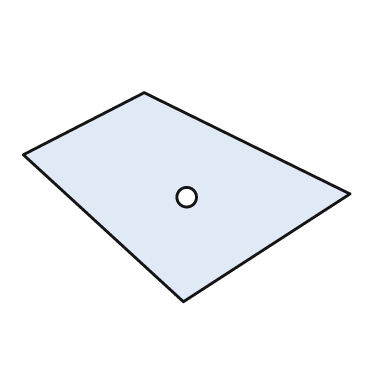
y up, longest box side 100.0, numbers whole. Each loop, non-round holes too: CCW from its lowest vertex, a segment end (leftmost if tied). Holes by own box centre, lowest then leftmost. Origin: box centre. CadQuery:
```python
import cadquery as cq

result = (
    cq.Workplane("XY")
    .moveTo(-1.0, -32.0)
    .lineTo(50.0, 1.0)
    .lineTo(-13.0, 32.0)
    .lineTo(-50.0, 13.0)
    .close()
    .moveTo(0.0, 0.0)
    .circle(3.0)
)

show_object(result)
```